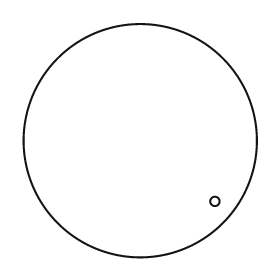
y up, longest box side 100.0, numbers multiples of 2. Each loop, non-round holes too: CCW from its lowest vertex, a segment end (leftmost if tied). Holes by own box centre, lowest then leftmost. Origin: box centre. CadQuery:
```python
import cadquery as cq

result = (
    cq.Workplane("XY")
    .moveTo(0.0, 0.0)
    .circle(50.0)
    .moveTo(32.0, -26.0)
    .circle(2.0)
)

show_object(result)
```